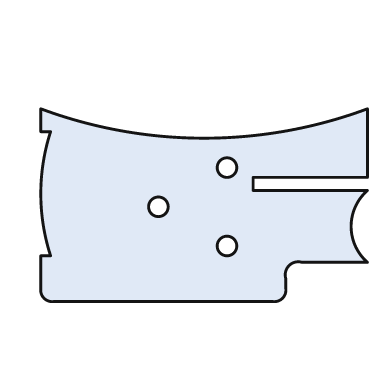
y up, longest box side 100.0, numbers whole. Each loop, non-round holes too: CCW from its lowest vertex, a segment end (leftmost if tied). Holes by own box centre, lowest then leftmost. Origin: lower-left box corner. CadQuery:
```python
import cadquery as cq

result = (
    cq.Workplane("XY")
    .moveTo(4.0, 0.0)
    .lineTo(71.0, 0.0)
    .threePointArc((74.0, 1.0), (75.0, 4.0))
    .lineTo(75.0, 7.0)
    .threePointArc((76.0, 11.0), (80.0, 12.0))
    .lineTo(100.0, 12.0)
    .threePointArc((95.0, 23.0), (100.0, 34.0))
    .lineTo(65.0, 34.0)
    .lineTo(65.0, 38.0)
    .lineTo(100.0, 38.0)
    .lineTo(100.0, 59.0)
    .threePointArc((50.0, 50.0), (0.0, 59.0))
    .lineTo(0.0, 52.0)
    .lineTo(3.0, 52.0)
    .threePointArc((0.0, 33.0), (3.0, 14.0))
    .lineTo(0.0, 14.0)
    .lineTo(0.0, 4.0)
    .threePointArc((1.0, 1.0), (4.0, 0.0))
    .close()
    .moveTo(57.0, 17.0)
    .circle(3.0)
    .moveTo(36.0, 29.0)
    .circle(3.0)
    .moveTo(57.0, 41.0)
    .circle(3.0)
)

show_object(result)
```